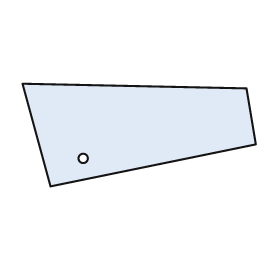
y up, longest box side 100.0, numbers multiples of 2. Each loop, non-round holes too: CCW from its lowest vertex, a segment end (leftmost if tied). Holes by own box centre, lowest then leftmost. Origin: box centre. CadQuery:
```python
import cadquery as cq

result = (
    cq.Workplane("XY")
    .moveTo(-38.0, -22.0)
    .lineTo(50.0, -4.0)
    .lineTo(46.0, 20.0)
    .lineTo(-50.0, 22.0)
    .close()
    .moveTo(-24.0, -10.0)
    .circle(2.0)
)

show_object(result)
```